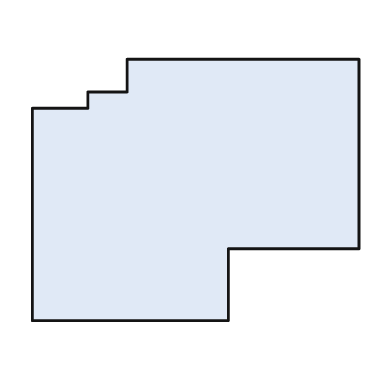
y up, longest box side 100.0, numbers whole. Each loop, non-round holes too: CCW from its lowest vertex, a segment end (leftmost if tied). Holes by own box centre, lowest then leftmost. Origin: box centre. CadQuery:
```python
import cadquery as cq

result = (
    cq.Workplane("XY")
    .moveTo(-50.0, -40.0)
    .lineTo(10.0, -40.0)
    .lineTo(10.0, -18.0)
    .lineTo(50.0, -18.0)
    .lineTo(50.0, 40.0)
    .lineTo(-21.0, 40.0)
    .lineTo(-21.0, 30.0)
    .lineTo(-33.0, 30.0)
    .lineTo(-33.0, 25.0)
    .lineTo(-50.0, 25.0)
    .close()
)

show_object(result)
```